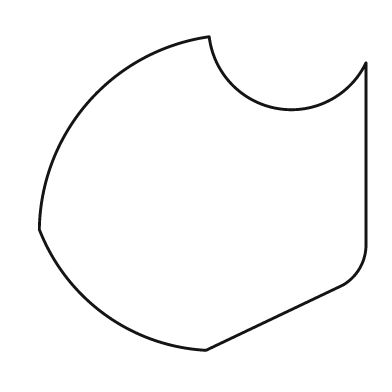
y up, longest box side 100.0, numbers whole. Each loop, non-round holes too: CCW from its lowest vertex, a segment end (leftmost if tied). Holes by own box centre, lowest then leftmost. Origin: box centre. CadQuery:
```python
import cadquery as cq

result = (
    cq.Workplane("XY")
    .moveTo(1.0, -48.0)
    .lineTo(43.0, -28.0)
    .threePointArc((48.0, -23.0), (50.0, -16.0))
    .lineTo(50.0, 40.0)
    .threePointArc((23.0, 26.0), (2.0, 48.0))
    .threePointArc((-35.0, 28.0), (-50.0, -11.0))
    .threePointArc((-30.0, -37.0), (1.0, -48.0))
    .close()
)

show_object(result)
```